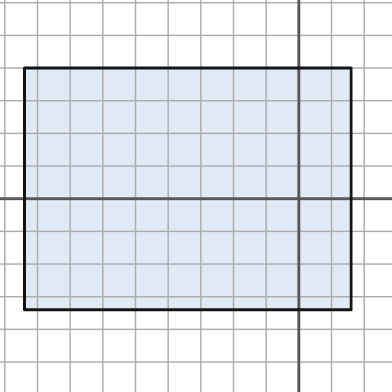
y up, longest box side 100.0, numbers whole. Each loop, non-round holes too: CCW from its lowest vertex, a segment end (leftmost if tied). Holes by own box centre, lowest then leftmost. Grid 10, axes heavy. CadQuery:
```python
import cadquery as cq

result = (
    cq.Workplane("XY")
    .moveTo(-84.0, -34.0)
    .lineTo(16.0, -34.0)
    .lineTo(16.0, 40.0)
    .lineTo(-84.0, 40.0)
    .close()
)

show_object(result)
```